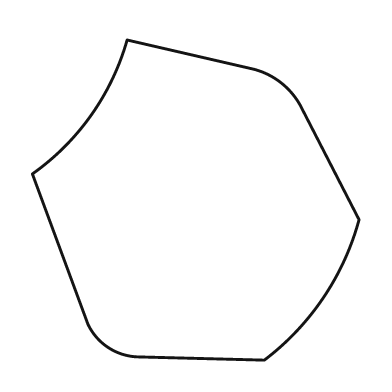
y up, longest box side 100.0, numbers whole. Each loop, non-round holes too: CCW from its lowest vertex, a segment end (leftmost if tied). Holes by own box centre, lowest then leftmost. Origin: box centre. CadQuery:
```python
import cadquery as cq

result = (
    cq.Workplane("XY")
    .moveTo(21.0, -49.0)
    .threePointArc((39.0, -30.0), (50.0, -6.0))
    .lineTo(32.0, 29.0)
    .threePointArc((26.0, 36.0), (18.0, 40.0))
    .lineTo(-21.0, 49.0)
    .threePointArc((-32.0, 26.0), (-50.0, 8.0))
    .lineTo(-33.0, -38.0)
    .threePointArc((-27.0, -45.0), (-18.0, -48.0))
    .close()
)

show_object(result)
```